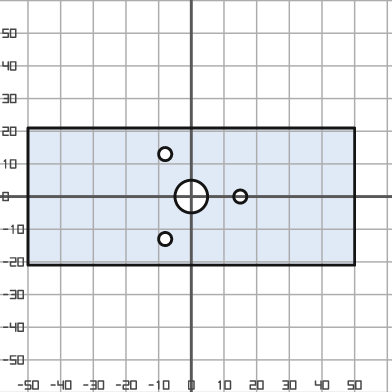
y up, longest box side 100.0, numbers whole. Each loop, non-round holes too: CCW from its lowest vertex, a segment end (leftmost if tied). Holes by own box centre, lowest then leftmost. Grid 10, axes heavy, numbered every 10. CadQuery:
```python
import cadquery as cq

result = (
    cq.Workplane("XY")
    .moveTo(-50.0, -21.0)
    .lineTo(50.0, -21.0)
    .lineTo(50.0, 21.0)
    .lineTo(-50.0, 21.0)
    .close()
    .moveTo(-8.0, -13.0)
    .circle(2.0)
    .moveTo(0.0, 0.0)
    .circle(5.0)
    .moveTo(15.0, 0.0)
    .circle(2.0)
    .moveTo(-8.0, 13.0)
    .circle(2.0)
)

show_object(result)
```